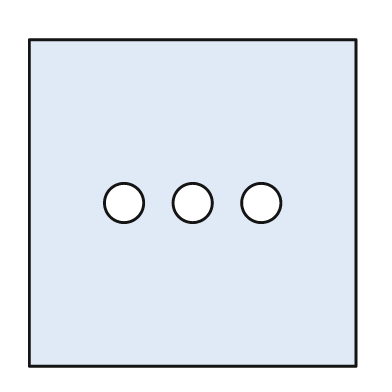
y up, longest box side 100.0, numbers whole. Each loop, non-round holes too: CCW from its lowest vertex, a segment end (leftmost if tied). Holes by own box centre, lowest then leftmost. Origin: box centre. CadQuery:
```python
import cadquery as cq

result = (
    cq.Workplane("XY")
    .moveTo(-50.0, -50.0)
    .lineTo(50.0, -50.0)
    .lineTo(50.0, 50.0)
    .lineTo(-50.0, 50.0)
    .close()
    .moveTo(-21.0, 0.0)
    .circle(6.0)
    .moveTo(0.0, 0.0)
    .circle(6.0)
    .moveTo(21.0, 0.0)
    .circle(6.0)
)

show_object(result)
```